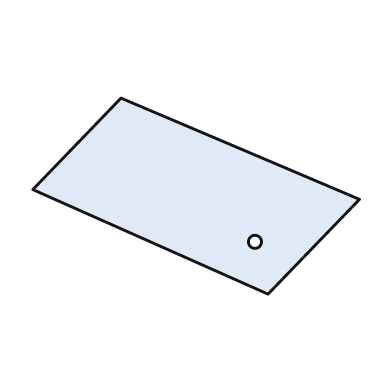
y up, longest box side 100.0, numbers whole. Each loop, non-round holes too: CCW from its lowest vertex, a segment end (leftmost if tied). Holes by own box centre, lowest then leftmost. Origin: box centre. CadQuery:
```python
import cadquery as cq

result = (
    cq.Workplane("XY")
    .moveTo(22.0, -30.0)
    .lineTo(50.0, -1.0)
    .lineTo(-23.0, 30.0)
    .lineTo(-50.0, 2.0)
    .close()
    .moveTo(18.0, -14.0)
    .circle(2.0)
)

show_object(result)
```